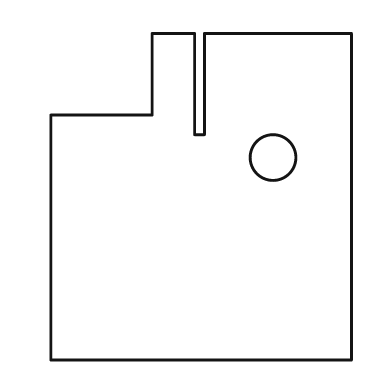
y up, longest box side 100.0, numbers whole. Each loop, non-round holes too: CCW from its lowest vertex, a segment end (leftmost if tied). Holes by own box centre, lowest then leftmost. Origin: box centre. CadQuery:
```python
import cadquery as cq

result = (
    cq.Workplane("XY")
    .moveTo(-46.0, -50.0)
    .lineTo(46.0, -50.0)
    .lineTo(46.0, 50.0)
    .lineTo(1.0, 50.0)
    .lineTo(1.0, 19.0)
    .lineTo(-2.0, 19.0)
    .lineTo(-2.0, 50.0)
    .lineTo(-15.0, 50.0)
    .lineTo(-15.0, 25.0)
    .lineTo(-46.0, 25.0)
    .close()
    .moveTo(22.0, 12.0)
    .circle(7.0)
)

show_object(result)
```